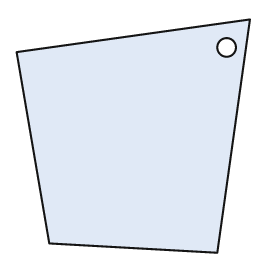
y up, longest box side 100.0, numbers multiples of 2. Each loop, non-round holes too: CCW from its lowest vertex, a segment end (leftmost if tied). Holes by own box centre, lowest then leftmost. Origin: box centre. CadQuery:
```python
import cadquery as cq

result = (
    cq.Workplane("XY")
    .moveTo(36.0, -50.0)
    .lineTo(50.0, 50.0)
    .lineTo(-50.0, 36.0)
    .lineTo(-36.0, -46.0)
    .close()
    .moveTo(40.0, 38.0)
    .circle(4.0)
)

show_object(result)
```